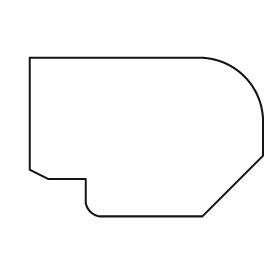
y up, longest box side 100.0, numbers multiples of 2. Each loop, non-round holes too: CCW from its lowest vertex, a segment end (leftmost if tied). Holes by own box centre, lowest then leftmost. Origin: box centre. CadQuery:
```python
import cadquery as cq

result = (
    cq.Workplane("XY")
    .moveTo(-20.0, -34.0)
    .lineTo(24.0, -34.0)
    .lineTo(50.0, -8.0)
    .lineTo(50.0, 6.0)
    .threePointArc((42.0, 26.0), (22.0, 34.0))
    .lineTo(-50.0, 34.0)
    .lineTo(-50.0, -14.0)
    .lineTo(-42.0, -18.0)
    .lineTo(-26.0, -18.0)
    .lineTo(-26.0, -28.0)
    .threePointArc((-24.0, -32.0), (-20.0, -34.0))
    .close()
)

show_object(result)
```